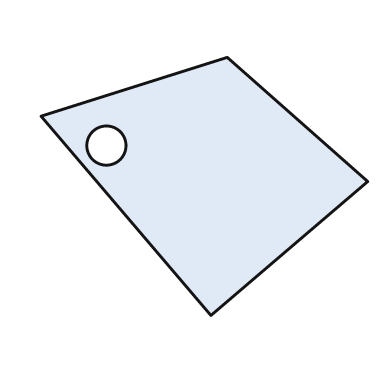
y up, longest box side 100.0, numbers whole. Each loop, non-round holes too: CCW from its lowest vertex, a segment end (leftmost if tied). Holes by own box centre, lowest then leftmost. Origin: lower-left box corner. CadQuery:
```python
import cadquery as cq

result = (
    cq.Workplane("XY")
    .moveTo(52.0, 0.0)
    .lineTo(100.0, 41.0)
    .lineTo(57.0, 79.0)
    .lineTo(0.0, 61.0)
    .close()
    .moveTo(20.0, 52.0)
    .circle(6.0)
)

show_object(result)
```